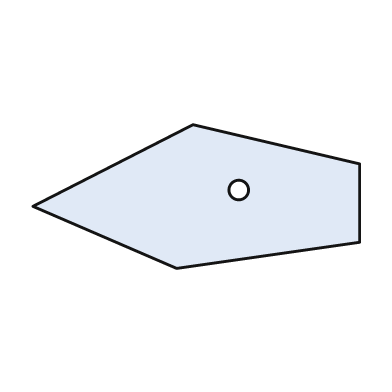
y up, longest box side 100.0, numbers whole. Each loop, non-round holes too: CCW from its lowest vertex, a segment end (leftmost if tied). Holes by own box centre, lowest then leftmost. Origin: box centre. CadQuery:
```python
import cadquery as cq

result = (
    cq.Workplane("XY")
    .moveTo(-6.0, -22.0)
    .lineTo(50.0, -14.0)
    .lineTo(50.0, 10.0)
    .lineTo(-1.0, 22.0)
    .lineTo(-50.0, -3.0)
    .close()
    .moveTo(13.0, 2.0)
    .circle(3.0)
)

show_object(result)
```